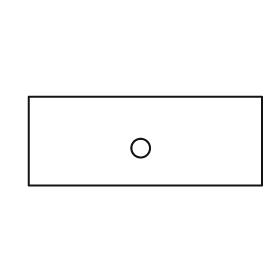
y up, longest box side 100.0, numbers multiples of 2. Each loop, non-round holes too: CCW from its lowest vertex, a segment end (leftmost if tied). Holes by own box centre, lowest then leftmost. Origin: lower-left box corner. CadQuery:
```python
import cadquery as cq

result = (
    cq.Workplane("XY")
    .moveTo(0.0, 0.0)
    .lineTo(100.0, 0.0)
    .lineTo(100.0, 38.0)
    .lineTo(0.0, 38.0)
    .close()
    .moveTo(48.0, 16.0)
    .circle(4.0)
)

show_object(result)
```